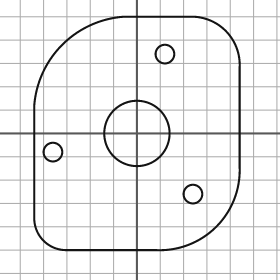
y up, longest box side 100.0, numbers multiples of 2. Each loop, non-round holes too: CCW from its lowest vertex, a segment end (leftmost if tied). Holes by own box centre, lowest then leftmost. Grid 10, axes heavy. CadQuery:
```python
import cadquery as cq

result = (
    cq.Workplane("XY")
    .moveTo(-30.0, -50.0)
    .lineTo(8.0, -50.0)
    .threePointArc((34.0, -40.0), (44.0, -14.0))
    .lineTo(44.0, 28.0)
    .threePointArc((38.0, 44.0), (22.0, 50.0))
    .lineTo(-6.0, 50.0)
    .threePointArc((-32.0, 38.0), (-44.0, 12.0))
    .lineTo(-44.0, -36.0)
    .threePointArc((-40.0, -46.0), (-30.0, -50.0))
    .close()
    .moveTo(24.0, -26.0)
    .circle(4.0)
    .moveTo(-36.0, -8.0)
    .circle(4.0)
    .moveTo(0.0, 0.0)
    .circle(14.0)
    .moveTo(12.0, 34.0)
    .circle(4.0)
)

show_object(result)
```